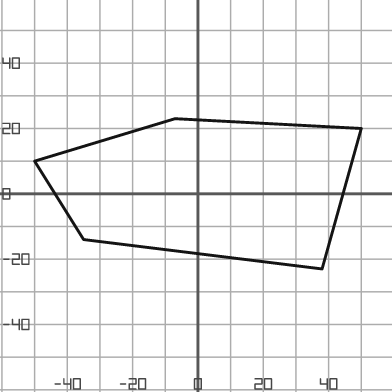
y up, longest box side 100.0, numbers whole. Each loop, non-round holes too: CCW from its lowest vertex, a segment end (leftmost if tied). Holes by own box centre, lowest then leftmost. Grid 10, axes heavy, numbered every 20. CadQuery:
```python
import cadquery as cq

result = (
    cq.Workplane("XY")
    .moveTo(38.0, -23.0)
    .lineTo(50.0, 20.0)
    .lineTo(-7.0, 23.0)
    .lineTo(-50.0, 10.0)
    .lineTo(-35.0, -14.0)
    .close()
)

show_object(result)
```